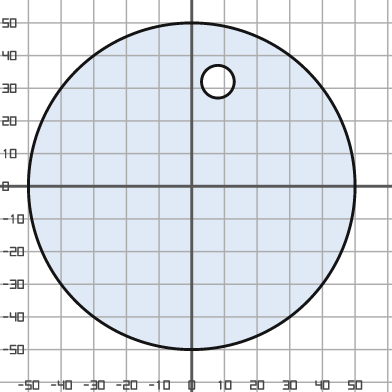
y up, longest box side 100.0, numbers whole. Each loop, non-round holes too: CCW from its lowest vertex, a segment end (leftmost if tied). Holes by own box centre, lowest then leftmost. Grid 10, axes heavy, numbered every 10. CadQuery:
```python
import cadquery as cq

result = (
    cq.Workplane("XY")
    .moveTo(0.0, 0.0)
    .circle(50.0)
    .moveTo(8.0, 32.0)
    .circle(5.0)
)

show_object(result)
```